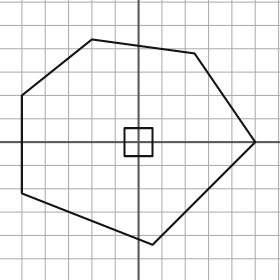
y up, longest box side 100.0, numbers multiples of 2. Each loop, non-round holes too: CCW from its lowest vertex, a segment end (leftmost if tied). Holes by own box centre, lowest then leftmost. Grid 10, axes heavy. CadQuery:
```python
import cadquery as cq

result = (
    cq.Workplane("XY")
    .moveTo(6.0, -44.0)
    .lineTo(50.0, 0.0)
    .lineTo(24.0, 38.0)
    .lineTo(-20.0, 44.0)
    .lineTo(-50.0, 20.0)
    .lineTo(-50.0, -22.0)
    .close()
    .moveTo(-6.0, -6.0)
    .lineTo(6.0, -6.0)
    .lineTo(6.0, 6.0)
    .lineTo(-6.0, 6.0)
    .close()
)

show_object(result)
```